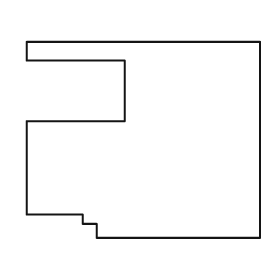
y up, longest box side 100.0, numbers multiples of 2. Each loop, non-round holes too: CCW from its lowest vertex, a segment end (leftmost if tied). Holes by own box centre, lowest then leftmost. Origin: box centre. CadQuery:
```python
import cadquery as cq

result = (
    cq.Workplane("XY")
    .moveTo(-20.0, -42.0)
    .lineTo(50.0, -42.0)
    .lineTo(50.0, 42.0)
    .lineTo(-50.0, 42.0)
    .lineTo(-50.0, 34.0)
    .lineTo(-8.0, 34.0)
    .lineTo(-8.0, 8.0)
    .lineTo(-50.0, 8.0)
    .lineTo(-50.0, -32.0)
    .lineTo(-26.0, -32.0)
    .lineTo(-26.0, -36.0)
    .lineTo(-20.0, -36.0)
    .close()
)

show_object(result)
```